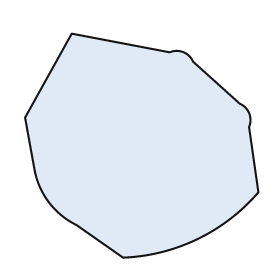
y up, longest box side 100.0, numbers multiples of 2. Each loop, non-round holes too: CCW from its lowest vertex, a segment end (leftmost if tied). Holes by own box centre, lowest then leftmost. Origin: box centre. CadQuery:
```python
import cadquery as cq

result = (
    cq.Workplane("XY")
    .moveTo(-8.0, -48.0)
    .threePointArc((24.0, -40.0), (50.0, -20.0))
    .lineTo(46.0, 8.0)
    .threePointArc((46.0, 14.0), (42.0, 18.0))
    .lineTo(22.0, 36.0)
    .threePointArc((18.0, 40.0), (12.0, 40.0))
    .lineTo(-30.0, 48.0)
    .lineTo(-50.0, 12.0)
    .lineTo(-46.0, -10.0)
    .threePointArc((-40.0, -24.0), (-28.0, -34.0))
    .close()
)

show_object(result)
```